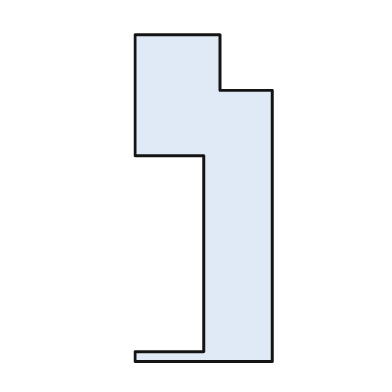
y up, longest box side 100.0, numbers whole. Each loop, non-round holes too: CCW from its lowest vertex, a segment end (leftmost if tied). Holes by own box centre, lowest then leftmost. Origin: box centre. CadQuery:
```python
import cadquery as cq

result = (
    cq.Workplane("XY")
    .moveTo(-21.0, -50.0)
    .lineTo(21.0, -50.0)
    .lineTo(21.0, 33.0)
    .lineTo(5.0, 33.0)
    .lineTo(5.0, 50.0)
    .lineTo(-21.0, 50.0)
    .lineTo(-21.0, 13.0)
    .lineTo(0.0, 13.0)
    .lineTo(0.0, -47.0)
    .lineTo(-21.0, -47.0)
    .close()
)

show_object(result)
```